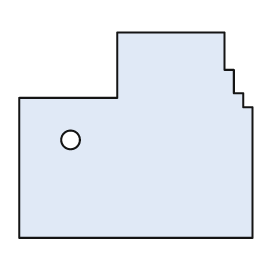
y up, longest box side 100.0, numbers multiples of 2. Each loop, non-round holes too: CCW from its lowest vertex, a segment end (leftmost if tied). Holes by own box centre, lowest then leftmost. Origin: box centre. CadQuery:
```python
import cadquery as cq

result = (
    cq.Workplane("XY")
    .moveTo(-50.0, -44.0)
    .lineTo(50.0, -44.0)
    .lineTo(50.0, 12.0)
    .lineTo(46.0, 12.0)
    .lineTo(46.0, 18.0)
    .lineTo(42.0, 18.0)
    .lineTo(42.0, 28.0)
    .lineTo(38.0, 28.0)
    .lineTo(38.0, 44.0)
    .lineTo(-8.0, 44.0)
    .lineTo(-8.0, 16.0)
    .lineTo(-50.0, 16.0)
    .close()
    .moveTo(-28.0, -2.0)
    .circle(4.0)
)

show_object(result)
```